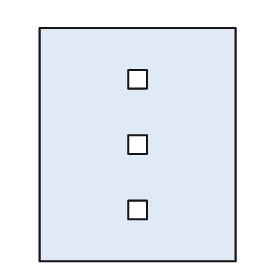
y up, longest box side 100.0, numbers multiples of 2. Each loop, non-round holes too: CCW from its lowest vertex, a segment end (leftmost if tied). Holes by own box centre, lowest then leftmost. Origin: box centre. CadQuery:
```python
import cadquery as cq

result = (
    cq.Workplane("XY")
    .moveTo(-42.0, -50.0)
    .lineTo(42.0, -50.0)
    .lineTo(42.0, 50.0)
    .lineTo(-42.0, 50.0)
    .close()
    .moveTo(-4.0, -32.0)
    .lineTo(4.0, -32.0)
    .lineTo(4.0, -24.0)
    .lineTo(-4.0, -24.0)
    .close()
    .moveTo(-4.0, -4.0)
    .lineTo(4.0, -4.0)
    .lineTo(4.0, 4.0)
    .lineTo(-4.0, 4.0)
    .close()
    .moveTo(-4.0, 24.0)
    .lineTo(4.0, 24.0)
    .lineTo(4.0, 32.0)
    .lineTo(-4.0, 32.0)
    .close()
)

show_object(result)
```